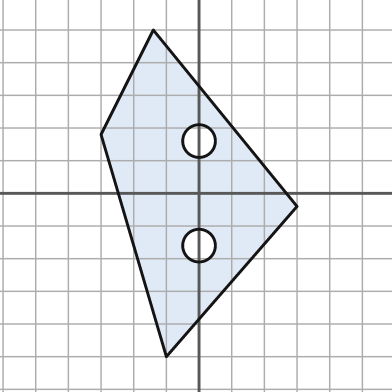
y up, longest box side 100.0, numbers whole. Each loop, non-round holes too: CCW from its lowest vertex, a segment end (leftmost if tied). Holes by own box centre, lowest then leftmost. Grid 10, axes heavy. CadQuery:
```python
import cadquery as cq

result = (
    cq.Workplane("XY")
    .moveTo(-10.0, -50.0)
    .lineTo(30.0, -4.0)
    .lineTo(-14.0, 50.0)
    .lineTo(-30.0, 18.0)
    .close()
    .moveTo(0.0, -16.0)
    .circle(5.0)
    .moveTo(0.0, 16.0)
    .circle(5.0)
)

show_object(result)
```